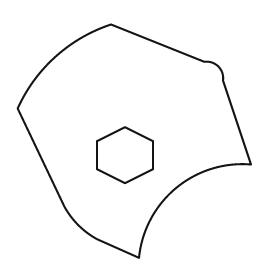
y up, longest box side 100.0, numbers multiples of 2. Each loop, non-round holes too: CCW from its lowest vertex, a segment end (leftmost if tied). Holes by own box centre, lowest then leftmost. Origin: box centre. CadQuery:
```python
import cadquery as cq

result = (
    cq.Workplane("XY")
    .moveTo(2.0, -50.0)
    .threePointArc((18.0, -20.0), (50.0, -10.0))
    .lineTo(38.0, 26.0)
    .threePointArc((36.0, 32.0), (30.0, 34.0))
    .lineTo(-10.0, 50.0)
    .threePointArc((-34.0, 36.0), (-50.0, 14.0))
    .lineTo(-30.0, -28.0)
    .threePointArc((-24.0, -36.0), (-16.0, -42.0))
    .close()
    .moveTo(-4.0, -18.0)
    .lineTo(8.0, -12.0)
    .lineTo(8.0, 0.0)
    .lineTo(-4.0, 6.0)
    .lineTo(-16.0, 0.0)
    .lineTo(-16.0, -12.0)
    .close()
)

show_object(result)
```